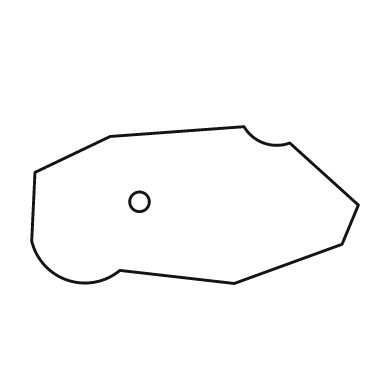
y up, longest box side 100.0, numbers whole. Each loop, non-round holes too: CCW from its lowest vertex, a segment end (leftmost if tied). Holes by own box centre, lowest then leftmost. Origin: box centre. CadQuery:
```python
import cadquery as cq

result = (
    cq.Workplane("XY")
    .moveTo(12.0, -24.0)
    .lineTo(45.0, -12.0)
    .lineTo(50.0, 0.0)
    .lineTo(29.0, 19.0)
    .threePointArc((21.0, 19.0), (15.0, 24.0))
    .lineTo(-26.0, 21.0)
    .lineTo(-49.0, 10.0)
    .lineTo(-50.0, -11.0)
    .threePointArc((-39.0, -23.0), (-23.0, -20.0))
    .close()
    .moveTo(-17.0, 1.0)
    .circle(3.0)
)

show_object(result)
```